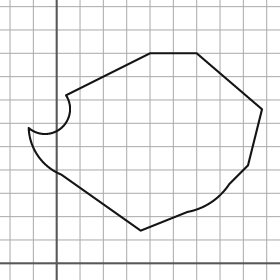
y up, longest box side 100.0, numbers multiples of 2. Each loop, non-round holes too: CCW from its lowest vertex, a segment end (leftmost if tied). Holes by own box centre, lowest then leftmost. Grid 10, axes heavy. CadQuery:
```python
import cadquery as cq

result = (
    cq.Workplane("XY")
    .moveTo(36.0, 14.0)
    .lineTo(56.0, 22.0)
    .threePointArc((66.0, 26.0), (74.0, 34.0))
    .lineTo(82.0, 42.0)
    .lineTo(88.0, 66.0)
    .lineTo(60.0, 90.0)
    .lineTo(40.0, 90.0)
    .lineTo(4.0, 72.0)
    .threePointArc((2.0, 58.0), (-12.0, 58.0))
    .threePointArc((-8.0, 46.0), (2.0, 38.0))
    .close()
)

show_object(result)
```